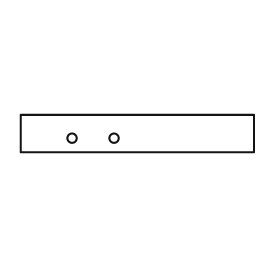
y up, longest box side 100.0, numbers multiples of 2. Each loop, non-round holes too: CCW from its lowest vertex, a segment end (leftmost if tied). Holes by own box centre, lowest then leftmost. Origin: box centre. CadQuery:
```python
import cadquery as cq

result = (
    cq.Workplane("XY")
    .moveTo(-50.0, -8.0)
    .lineTo(50.0, -8.0)
    .lineTo(50.0, 8.0)
    .lineTo(-50.0, 8.0)
    .close()
    .moveTo(-28.0, -2.0)
    .circle(2.0)
    .moveTo(-10.0, -2.0)
    .circle(2.0)
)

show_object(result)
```